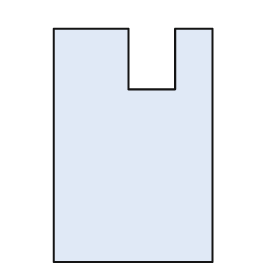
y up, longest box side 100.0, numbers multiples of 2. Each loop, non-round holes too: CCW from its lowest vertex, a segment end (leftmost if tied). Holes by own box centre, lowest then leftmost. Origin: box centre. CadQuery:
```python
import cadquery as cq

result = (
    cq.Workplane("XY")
    .moveTo(-34.0, -50.0)
    .lineTo(34.0, -50.0)
    .lineTo(34.0, 50.0)
    .lineTo(18.0, 50.0)
    .lineTo(18.0, 24.0)
    .lineTo(-2.0, 24.0)
    .lineTo(-2.0, 50.0)
    .lineTo(-34.0, 50.0)
    .close()
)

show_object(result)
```